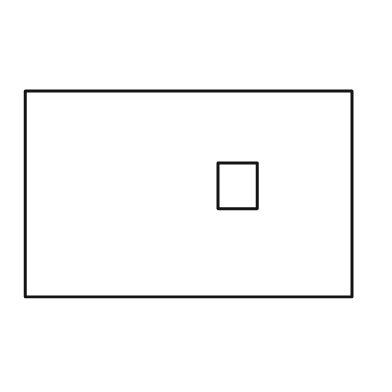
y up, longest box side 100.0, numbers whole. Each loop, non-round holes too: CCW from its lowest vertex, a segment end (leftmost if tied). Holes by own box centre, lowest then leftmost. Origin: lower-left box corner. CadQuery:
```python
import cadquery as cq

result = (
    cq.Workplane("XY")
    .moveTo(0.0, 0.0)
    .lineTo(100.0, 0.0)
    .lineTo(100.0, 63.0)
    .lineTo(0.0, 63.0)
    .close()
    .moveTo(59.0, 27.0)
    .lineTo(71.0, 27.0)
    .lineTo(71.0, 41.0)
    .lineTo(59.0, 41.0)
    .close()
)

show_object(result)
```